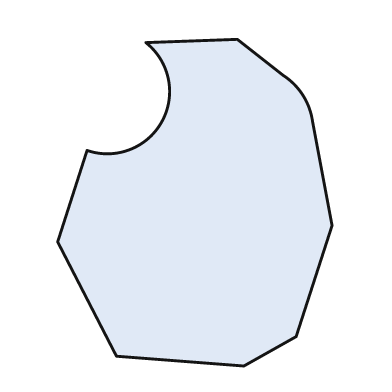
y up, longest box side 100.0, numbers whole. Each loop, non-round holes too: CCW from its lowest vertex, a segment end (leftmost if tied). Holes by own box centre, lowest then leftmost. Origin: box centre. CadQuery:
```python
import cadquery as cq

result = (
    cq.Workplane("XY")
    .moveTo(15.0, -50.0)
    .lineTo(31.0, -41.0)
    .lineTo(42.0, -7.0)
    .lineTo(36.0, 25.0)
    .threePointArc((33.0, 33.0), (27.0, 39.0))
    .lineTo(13.0, 50.0)
    .lineTo(-15.0, 49.0)
    .threePointArc((-10.0, 25.0), (-33.0, 16.0))
    .lineTo(-42.0, -12.0)
    .lineTo(-24.0, -47.0)
    .close()
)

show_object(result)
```